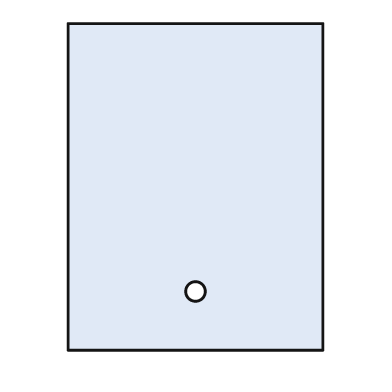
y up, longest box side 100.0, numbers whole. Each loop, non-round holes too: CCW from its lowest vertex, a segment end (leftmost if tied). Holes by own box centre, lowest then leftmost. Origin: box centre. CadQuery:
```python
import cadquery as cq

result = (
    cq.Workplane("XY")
    .moveTo(-39.0, -50.0)
    .lineTo(39.0, -50.0)
    .lineTo(39.0, 50.0)
    .lineTo(-39.0, 50.0)
    .close()
    .moveTo(0.0, -32.0)
    .circle(3.0)
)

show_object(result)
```